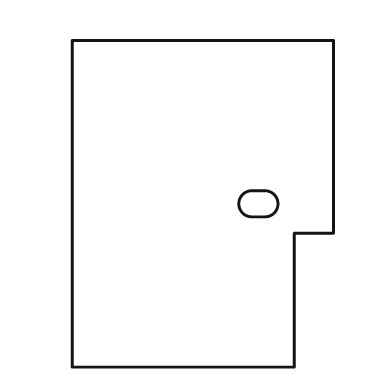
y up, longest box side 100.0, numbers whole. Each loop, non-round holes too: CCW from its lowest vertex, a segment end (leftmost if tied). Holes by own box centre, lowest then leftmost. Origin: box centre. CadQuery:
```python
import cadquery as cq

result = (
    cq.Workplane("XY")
    .moveTo(-40.0, -50.0)
    .lineTo(28.0, -50.0)
    .lineTo(28.0, -9.0)
    .lineTo(40.0, -9.0)
    .lineTo(40.0, 50.0)
    .lineTo(-40.0, 50.0)
    .close()
    .moveTo(15.0, -4.0)
    .lineTo(19.0, -4.0)
    .threePointArc((23.0, 0.0), (19.0, 4.0))
    .lineTo(15.0, 4.0)
    .threePointArc((11.0, 0.0), (15.0, -4.0))
    .close()
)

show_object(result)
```